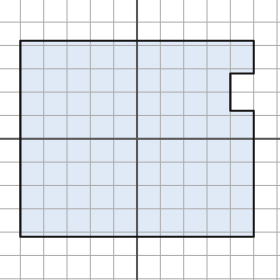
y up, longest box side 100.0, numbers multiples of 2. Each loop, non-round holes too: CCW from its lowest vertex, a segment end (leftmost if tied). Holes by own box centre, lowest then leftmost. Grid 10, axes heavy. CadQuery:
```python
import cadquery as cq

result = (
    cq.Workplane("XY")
    .moveTo(-50.0, -42.0)
    .lineTo(50.0, -42.0)
    .lineTo(50.0, 12.0)
    .lineTo(40.0, 12.0)
    .lineTo(40.0, 28.0)
    .lineTo(50.0, 28.0)
    .lineTo(50.0, 42.0)
    .lineTo(-50.0, 42.0)
    .close()
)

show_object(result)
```